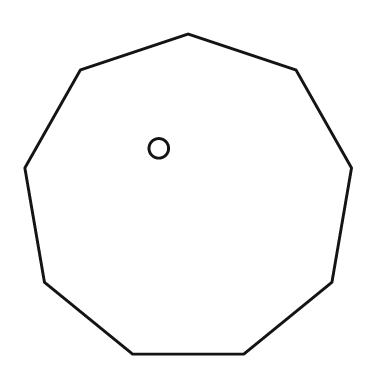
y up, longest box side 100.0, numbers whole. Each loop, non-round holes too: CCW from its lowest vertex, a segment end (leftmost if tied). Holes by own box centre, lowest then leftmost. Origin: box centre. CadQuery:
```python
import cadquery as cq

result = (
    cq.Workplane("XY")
    .moveTo(-17.0, -49.0)
    .lineTo(17.0, -49.0)
    .lineTo(44.0, -27.0)
    .lineTo(50.0, 8.0)
    .lineTo(33.0, 38.0)
    .lineTo(0.0, 49.0)
    .lineTo(-33.0, 38.0)
    .lineTo(-50.0, 8.0)
    .lineTo(-44.0, -27.0)
    .close()
    .moveTo(-9.0, 14.0)
    .circle(3.0)
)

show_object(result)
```